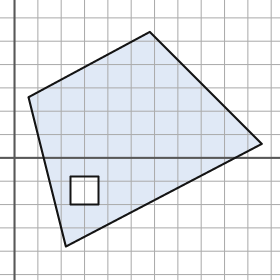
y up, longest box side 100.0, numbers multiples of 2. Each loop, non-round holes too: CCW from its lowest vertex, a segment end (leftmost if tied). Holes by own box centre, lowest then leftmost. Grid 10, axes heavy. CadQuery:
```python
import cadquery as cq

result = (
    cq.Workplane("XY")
    .moveTo(22.0, -38.0)
    .lineTo(106.0, 6.0)
    .lineTo(58.0, 54.0)
    .lineTo(6.0, 26.0)
    .close()
    .moveTo(24.0, -20.0)
    .lineTo(36.0, -20.0)
    .lineTo(36.0, -8.0)
    .lineTo(24.0, -8.0)
    .close()
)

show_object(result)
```